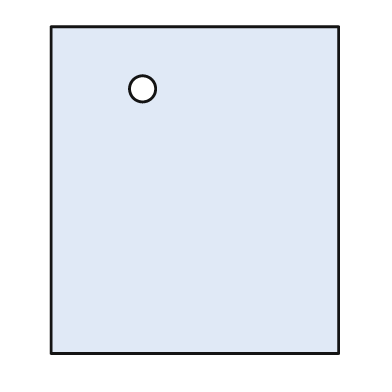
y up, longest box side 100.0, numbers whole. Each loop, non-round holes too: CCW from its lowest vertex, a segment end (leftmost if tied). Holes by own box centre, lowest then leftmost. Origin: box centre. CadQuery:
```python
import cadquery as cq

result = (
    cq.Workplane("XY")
    .moveTo(-44.0, -50.0)
    .lineTo(44.0, -50.0)
    .lineTo(44.0, 50.0)
    .lineTo(-44.0, 50.0)
    .close()
    .moveTo(-16.0, 31.0)
    .circle(4.0)
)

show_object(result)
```